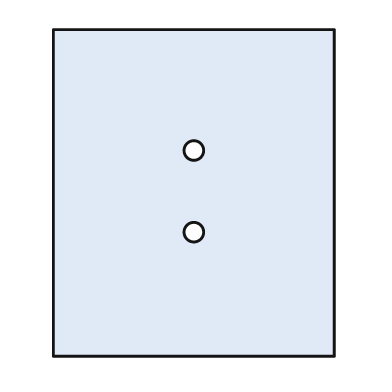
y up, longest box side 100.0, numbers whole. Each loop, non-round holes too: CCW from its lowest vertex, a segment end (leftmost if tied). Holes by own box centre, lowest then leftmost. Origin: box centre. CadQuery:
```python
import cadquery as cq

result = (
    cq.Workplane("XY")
    .moveTo(-43.0, -50.0)
    .lineTo(43.0, -50.0)
    .lineTo(43.0, 50.0)
    .lineTo(-43.0, 50.0)
    .close()
    .moveTo(0.0, -12.0)
    .circle(3.0)
    .moveTo(0.0, 13.0)
    .circle(3.0)
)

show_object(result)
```